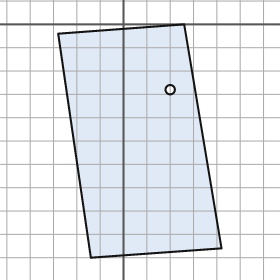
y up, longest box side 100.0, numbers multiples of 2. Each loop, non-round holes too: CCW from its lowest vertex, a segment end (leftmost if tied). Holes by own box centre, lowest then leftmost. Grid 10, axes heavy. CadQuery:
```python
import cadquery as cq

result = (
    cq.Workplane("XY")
    .moveTo(-14.0, -100.0)
    .lineTo(42.0, -96.0)
    .lineTo(26.0, 0.0)
    .lineTo(-28.0, -4.0)
    .close()
    .moveTo(20.0, -28.0)
    .circle(2.0)
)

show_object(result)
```